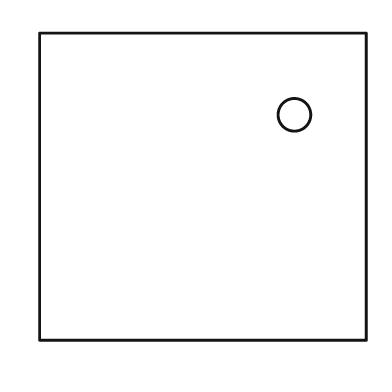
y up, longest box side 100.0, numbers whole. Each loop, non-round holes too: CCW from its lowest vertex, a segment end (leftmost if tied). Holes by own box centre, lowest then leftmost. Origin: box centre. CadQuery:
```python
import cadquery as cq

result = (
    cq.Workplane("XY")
    .moveTo(-50.0, -47.0)
    .lineTo(50.0, -47.0)
    .lineTo(50.0, 47.0)
    .lineTo(-50.0, 47.0)
    .close()
    .moveTo(28.0, 22.0)
    .circle(5.0)
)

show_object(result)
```